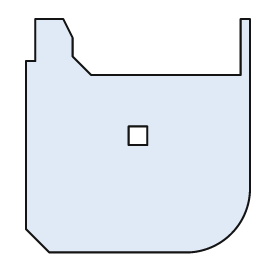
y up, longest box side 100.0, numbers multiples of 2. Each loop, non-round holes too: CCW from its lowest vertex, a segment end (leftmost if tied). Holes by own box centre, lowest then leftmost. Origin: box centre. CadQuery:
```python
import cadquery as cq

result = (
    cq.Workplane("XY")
    .moveTo(-38.0, -50.0)
    .lineTo(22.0, -50.0)
    .threePointArc((40.0, -42.0), (48.0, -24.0))
    .lineTo(48.0, 50.0)
    .lineTo(44.0, 50.0)
    .lineTo(44.0, 26.0)
    .lineTo(-20.0, 26.0)
    .lineTo(-28.0, 34.0)
    .lineTo(-28.0, 42.0)
    .lineTo(-32.0, 50.0)
    .lineTo(-44.0, 50.0)
    .lineTo(-44.0, 32.0)
    .lineTo(-48.0, 32.0)
    .lineTo(-48.0, -40.0)
    .close()
    .moveTo(-4.0, -4.0)
    .lineTo(4.0, -4.0)
    .lineTo(4.0, 4.0)
    .lineTo(-4.0, 4.0)
    .close()
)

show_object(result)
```